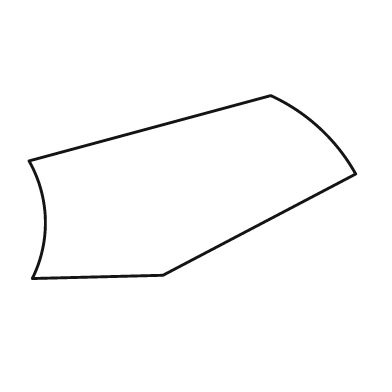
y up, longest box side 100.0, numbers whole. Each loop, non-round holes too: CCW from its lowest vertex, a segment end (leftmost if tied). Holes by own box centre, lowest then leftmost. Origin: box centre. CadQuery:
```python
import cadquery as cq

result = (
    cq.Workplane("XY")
    .moveTo(-49.0, -28.0)
    .lineTo(-9.0, -27.0)
    .lineTo(50.0, 4.0)
    .threePointArc((39.0, 18.0), (24.0, 28.0))
    .lineTo(-50.0, 8.0)
    .threePointArc((-45.0, -10.0), (-49.0, -28.0))
    .close()
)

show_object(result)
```